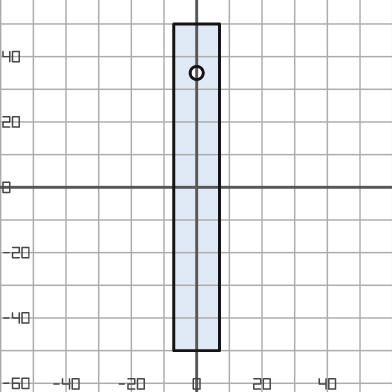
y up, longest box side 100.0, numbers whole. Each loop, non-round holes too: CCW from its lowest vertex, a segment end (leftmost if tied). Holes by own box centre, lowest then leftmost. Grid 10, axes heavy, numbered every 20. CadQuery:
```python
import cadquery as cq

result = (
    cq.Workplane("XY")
    .moveTo(-7.0, -50.0)
    .lineTo(7.0, -50.0)
    .lineTo(7.0, 50.0)
    .lineTo(-7.0, 50.0)
    .close()
    .moveTo(0.0, 35.0)
    .circle(2.0)
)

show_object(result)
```